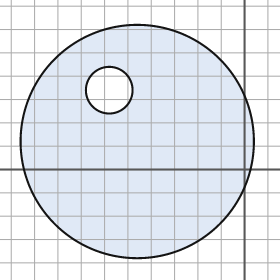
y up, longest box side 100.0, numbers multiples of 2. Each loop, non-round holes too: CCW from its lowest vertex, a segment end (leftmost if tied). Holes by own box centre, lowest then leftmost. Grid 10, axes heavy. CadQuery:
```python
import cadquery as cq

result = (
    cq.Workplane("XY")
    .moveTo(-46.0, 12.0)
    .circle(50.0)
    .moveTo(-58.0, 34.0)
    .circle(10.0)
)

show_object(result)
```